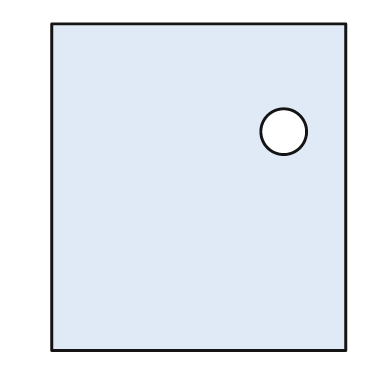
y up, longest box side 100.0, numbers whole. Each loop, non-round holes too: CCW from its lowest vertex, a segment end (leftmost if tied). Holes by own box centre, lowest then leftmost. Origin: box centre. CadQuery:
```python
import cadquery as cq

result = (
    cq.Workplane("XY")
    .moveTo(-45.0, -50.0)
    .lineTo(45.0, -50.0)
    .lineTo(45.0, 50.0)
    .lineTo(-45.0, 50.0)
    .close()
    .moveTo(26.0, 17.0)
    .circle(7.0)
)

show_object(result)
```